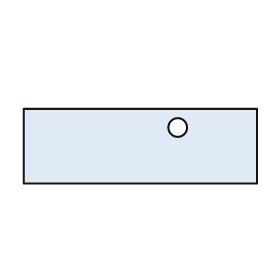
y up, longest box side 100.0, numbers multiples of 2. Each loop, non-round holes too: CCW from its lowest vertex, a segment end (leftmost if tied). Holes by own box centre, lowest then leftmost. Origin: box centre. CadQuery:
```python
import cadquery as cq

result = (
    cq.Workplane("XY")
    .moveTo(-50.0, -16.0)
    .lineTo(50.0, -16.0)
    .lineTo(50.0, 16.0)
    .lineTo(-50.0, 16.0)
    .close()
    .moveTo(16.0, 8.0)
    .circle(4.0)
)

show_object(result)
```